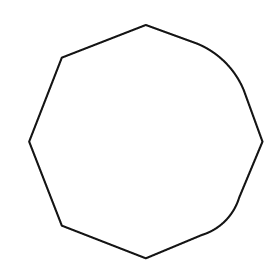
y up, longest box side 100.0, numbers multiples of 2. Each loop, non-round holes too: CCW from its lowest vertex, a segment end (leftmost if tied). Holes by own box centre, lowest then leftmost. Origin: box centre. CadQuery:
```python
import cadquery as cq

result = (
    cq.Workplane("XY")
    .moveTo(0.0, -50.0)
    .lineTo(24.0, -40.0)
    .threePointArc((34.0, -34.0), (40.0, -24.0))
    .lineTo(50.0, 0.0)
    .lineTo(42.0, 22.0)
    .threePointArc((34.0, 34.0), (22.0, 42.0))
    .lineTo(0.0, 50.0)
    .lineTo(-36.0, 36.0)
    .lineTo(-50.0, 0.0)
    .lineTo(-36.0, -36.0)
    .close()
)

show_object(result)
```